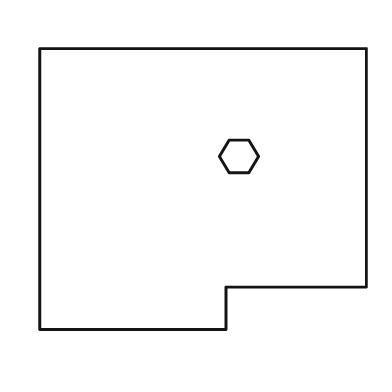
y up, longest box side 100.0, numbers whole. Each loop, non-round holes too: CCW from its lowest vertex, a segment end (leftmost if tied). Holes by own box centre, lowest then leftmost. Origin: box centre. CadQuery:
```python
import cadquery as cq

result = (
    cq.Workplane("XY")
    .moveTo(-50.0, -43.0)
    .lineTo(7.0, -43.0)
    .lineTo(7.0, -30.0)
    .lineTo(50.0, -30.0)
    .lineTo(50.0, 43.0)
    .lineTo(-50.0, 43.0)
    .close()
    .moveTo(8.0, 5.0)
    .lineTo(14.0, 5.0)
    .lineTo(17.0, 10.0)
    .lineTo(14.0, 15.0)
    .lineTo(8.0, 15.0)
    .lineTo(5.0, 10.0)
    .close()
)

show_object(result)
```